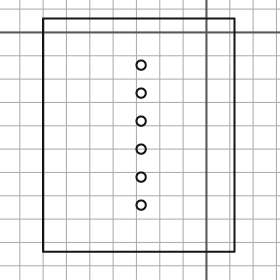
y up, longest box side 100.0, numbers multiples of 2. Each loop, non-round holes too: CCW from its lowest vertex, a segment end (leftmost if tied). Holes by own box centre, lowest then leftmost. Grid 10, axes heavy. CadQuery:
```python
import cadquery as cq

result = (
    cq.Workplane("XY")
    .moveTo(-70.0, -94.0)
    .lineTo(12.0, -94.0)
    .lineTo(12.0, 6.0)
    .lineTo(-70.0, 6.0)
    .close()
    .moveTo(-28.0, -74.0)
    .circle(2.0)
    .moveTo(-28.0, -62.0)
    .circle(2.0)
    .moveTo(-28.0, -50.0)
    .circle(2.0)
    .moveTo(-28.0, -38.0)
    .circle(2.0)
    .moveTo(-28.0, -26.0)
    .circle(2.0)
    .moveTo(-28.0, -14.0)
    .circle(2.0)
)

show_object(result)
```